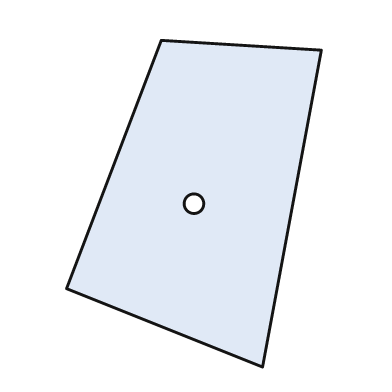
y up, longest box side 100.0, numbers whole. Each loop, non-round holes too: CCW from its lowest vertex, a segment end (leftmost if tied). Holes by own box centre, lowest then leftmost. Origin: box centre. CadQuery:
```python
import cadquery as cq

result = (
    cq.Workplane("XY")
    .moveTo(21.0, -50.0)
    .lineTo(39.0, 47.0)
    .lineTo(-10.0, 50.0)
    .lineTo(-39.0, -26.0)
    .close()
    .moveTo(0.0, 0.0)
    .circle(3.0)
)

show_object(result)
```